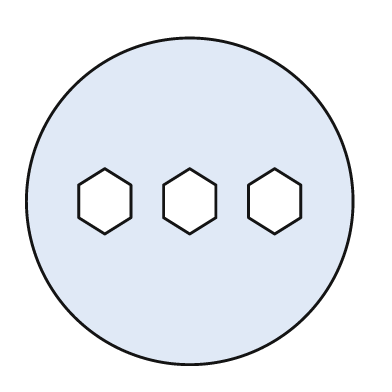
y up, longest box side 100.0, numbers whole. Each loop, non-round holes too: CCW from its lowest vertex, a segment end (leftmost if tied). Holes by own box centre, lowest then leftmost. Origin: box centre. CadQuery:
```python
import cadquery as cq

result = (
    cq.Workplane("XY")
    .moveTo(0.0, 0.0)
    .circle(50.0)
    .moveTo(-26.0, -10.0)
    .lineTo(-18.0, -5.0)
    .lineTo(-18.0, 5.0)
    .lineTo(-26.0, 10.0)
    .lineTo(-34.0, 5.0)
    .lineTo(-34.0, -5.0)
    .close()
    .moveTo(0.0, -10.0)
    .lineTo(8.0, -5.0)
    .lineTo(8.0, 5.0)
    .lineTo(0.0, 10.0)
    .lineTo(-8.0, 5.0)
    .lineTo(-8.0, -5.0)
    .close()
    .moveTo(26.0, -10.0)
    .lineTo(34.0, -5.0)
    .lineTo(34.0, 5.0)
    .lineTo(26.0, 10.0)
    .lineTo(18.0, 5.0)
    .lineTo(18.0, -5.0)
    .close()
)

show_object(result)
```